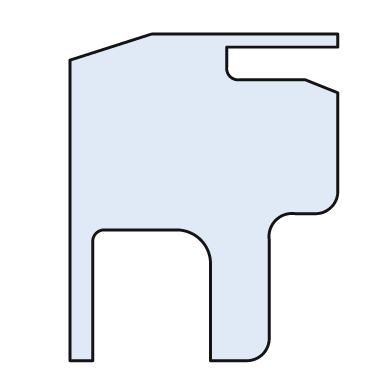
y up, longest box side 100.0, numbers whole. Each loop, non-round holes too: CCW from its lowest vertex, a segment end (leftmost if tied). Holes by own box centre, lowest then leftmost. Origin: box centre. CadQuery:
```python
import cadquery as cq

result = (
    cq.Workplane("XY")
    .moveTo(-41.0, -50.0)
    .lineTo(-34.0, -50.0)
    .lineTo(-34.0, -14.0)
    .threePointArc((-33.0, -11.0), (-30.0, -10.0))
    .lineTo(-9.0, -10.0)
    .threePointArc((-1.0, -13.0), (2.0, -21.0))
    .lineTo(2.0, -50.0)
    .lineTo(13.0, -50.0)
    .threePointArc((18.0, -48.0), (20.0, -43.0))
    .lineTo(20.0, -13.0)
    .threePointArc((22.0, -7.0), (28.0, -5.0))
    .lineTo(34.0, -5.0)
    .threePointArc((39.0, -3.0), (41.0, 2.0))
    .lineTo(41.0, 32.0)
    .lineTo(31.0, 36.0)
    .lineTo(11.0, 36.0)
    .threePointArc((8.0, 37.0), (7.0, 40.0))
    .lineTo(7.0, 46.0)
    .lineTo(41.0, 46.0)
    .lineTo(41.0, 50.0)
    .lineTo(-16.0, 50.0)
    .lineTo(-41.0, 42.0)
    .close()
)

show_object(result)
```